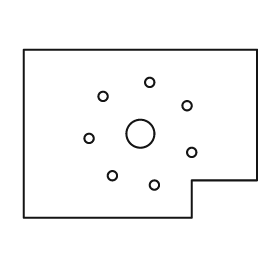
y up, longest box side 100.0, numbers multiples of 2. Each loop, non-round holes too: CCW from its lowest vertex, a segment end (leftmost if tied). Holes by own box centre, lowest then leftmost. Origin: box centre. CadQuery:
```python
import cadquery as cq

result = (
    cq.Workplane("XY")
    .moveTo(-50.0, -36.0)
    .lineTo(22.0, -36.0)
    .lineTo(22.0, -20.0)
    .lineTo(50.0, -20.0)
    .lineTo(50.0, 36.0)
    .lineTo(-50.0, 36.0)
    .close()
    .moveTo(6.0, -22.0)
    .circle(2.0)
    .moveTo(-12.0, -18.0)
    .circle(2.0)
    .moveTo(22.0, -8.0)
    .circle(2.0)
    .moveTo(-22.0, -2.0)
    .circle(2.0)
    .moveTo(0.0, 0.0)
    .circle(6.0)
    .moveTo(20.0, 12.0)
    .circle(2.0)
    .moveTo(-16.0, 16.0)
    .circle(2.0)
    .moveTo(4.0, 22.0)
    .circle(2.0)
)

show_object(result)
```